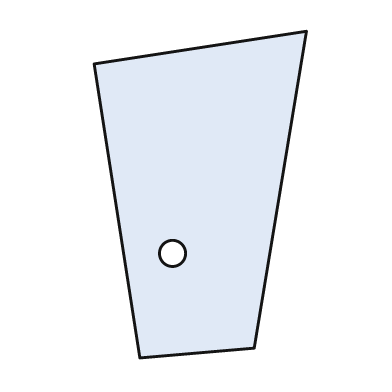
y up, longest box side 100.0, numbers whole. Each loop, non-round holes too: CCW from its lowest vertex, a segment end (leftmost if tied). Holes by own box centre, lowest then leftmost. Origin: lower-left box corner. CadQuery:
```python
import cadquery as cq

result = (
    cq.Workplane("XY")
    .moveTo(14.0, 0.0)
    .lineTo(49.0, 3.0)
    .lineTo(65.0, 100.0)
    .lineTo(0.0, 90.0)
    .close()
    .moveTo(24.0, 32.0)
    .circle(4.0)
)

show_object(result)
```